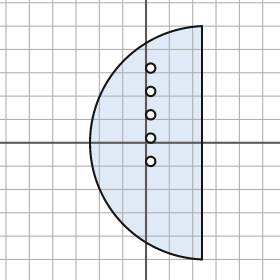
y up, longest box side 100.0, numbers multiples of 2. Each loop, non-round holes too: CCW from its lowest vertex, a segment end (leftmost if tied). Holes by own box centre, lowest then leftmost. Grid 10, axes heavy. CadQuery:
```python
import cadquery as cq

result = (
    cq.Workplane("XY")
    .moveTo(24.0, -50.0)
    .lineTo(24.0, 50.0)
    .threePointArc((-24.0, 0.0), (24.0, -50.0))
    .close()
    .moveTo(2.0, -8.0)
    .circle(2.0)
    .moveTo(2.0, 2.0)
    .circle(2.0)
    .moveTo(2.0, 12.0)
    .circle(2.0)
    .moveTo(2.0, 22.0)
    .circle(2.0)
    .moveTo(2.0, 32.0)
    .circle(2.0)
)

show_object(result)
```